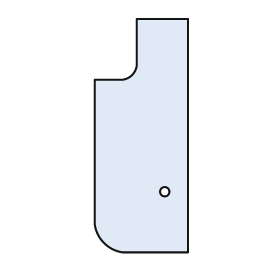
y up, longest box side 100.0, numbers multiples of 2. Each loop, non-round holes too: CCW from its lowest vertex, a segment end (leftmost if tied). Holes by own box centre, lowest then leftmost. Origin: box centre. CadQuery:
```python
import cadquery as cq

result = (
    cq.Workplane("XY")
    .moveTo(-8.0, -50.0)
    .lineTo(20.0, -50.0)
    .lineTo(20.0, 50.0)
    .lineTo(-2.0, 50.0)
    .lineTo(-2.0, 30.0)
    .threePointArc((-4.0, 26.0), (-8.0, 24.0))
    .lineTo(-20.0, 24.0)
    .lineTo(-20.0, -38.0)
    .threePointArc((-16.0, -46.0), (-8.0, -50.0))
    .close()
    .moveTo(10.0, -24.0)
    .circle(2.0)
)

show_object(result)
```